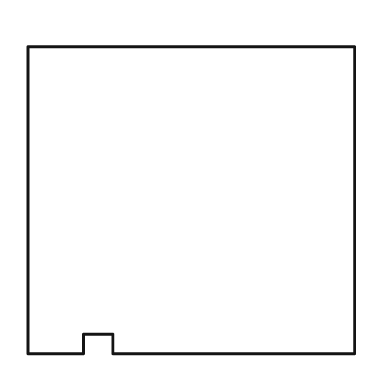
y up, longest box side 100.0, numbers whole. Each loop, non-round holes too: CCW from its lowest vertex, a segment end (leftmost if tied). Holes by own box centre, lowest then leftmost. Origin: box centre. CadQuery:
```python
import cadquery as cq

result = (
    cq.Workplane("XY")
    .moveTo(-50.0, -47.0)
    .lineTo(-33.0, -47.0)
    .lineTo(-33.0, -41.0)
    .lineTo(-24.0, -41.0)
    .lineTo(-24.0, -47.0)
    .lineTo(50.0, -47.0)
    .lineTo(50.0, 47.0)
    .lineTo(-50.0, 47.0)
    .close()
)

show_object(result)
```